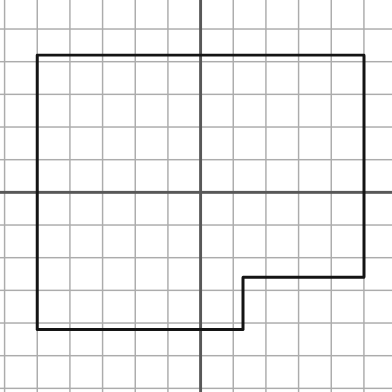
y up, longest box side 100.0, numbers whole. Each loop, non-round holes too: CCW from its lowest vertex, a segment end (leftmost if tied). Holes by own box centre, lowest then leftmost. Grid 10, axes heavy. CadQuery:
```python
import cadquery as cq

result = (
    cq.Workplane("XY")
    .moveTo(-50.0, -42.0)
    .lineTo(13.0, -42.0)
    .lineTo(13.0, -26.0)
    .lineTo(50.0, -26.0)
    .lineTo(50.0, 42.0)
    .lineTo(-50.0, 42.0)
    .close()
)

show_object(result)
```